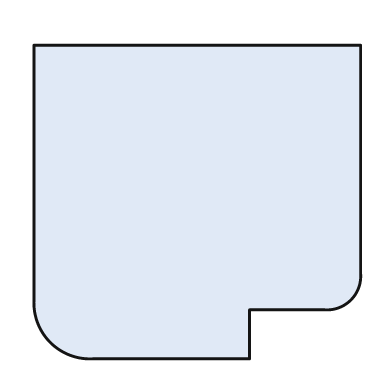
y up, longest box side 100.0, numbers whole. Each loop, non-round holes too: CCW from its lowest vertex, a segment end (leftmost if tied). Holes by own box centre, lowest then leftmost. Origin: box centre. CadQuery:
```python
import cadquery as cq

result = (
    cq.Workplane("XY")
    .moveTo(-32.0, -48.0)
    .lineTo(16.0, -48.0)
    .lineTo(16.0, -33.0)
    .lineTo(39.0, -33.0)
    .threePointArc((47.0, -30.0), (50.0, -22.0))
    .lineTo(50.0, 48.0)
    .lineTo(-50.0, 48.0)
    .lineTo(-50.0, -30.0)
    .threePointArc((-45.0, -43.0), (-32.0, -48.0))
    .close()
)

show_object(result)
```